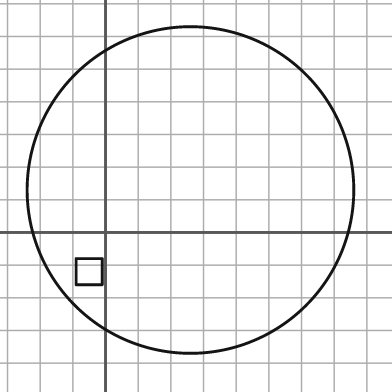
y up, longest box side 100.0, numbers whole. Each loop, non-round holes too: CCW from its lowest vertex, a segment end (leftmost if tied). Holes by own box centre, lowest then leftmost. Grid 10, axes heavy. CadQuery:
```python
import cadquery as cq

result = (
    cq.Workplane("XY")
    .moveTo(26.0, 13.0)
    .circle(50.0)
    .moveTo(-9.0, -16.0)
    .lineTo(-1.0, -16.0)
    .lineTo(-1.0, -8.0)
    .lineTo(-9.0, -8.0)
    .close()
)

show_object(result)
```